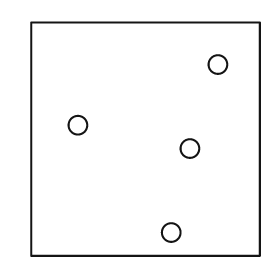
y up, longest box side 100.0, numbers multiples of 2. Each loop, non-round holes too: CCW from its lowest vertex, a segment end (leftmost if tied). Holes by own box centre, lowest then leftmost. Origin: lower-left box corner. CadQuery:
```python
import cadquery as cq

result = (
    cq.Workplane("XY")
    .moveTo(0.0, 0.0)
    .lineTo(98.0, 0.0)
    .lineTo(98.0, 100.0)
    .lineTo(0.0, 100.0)
    .close()
    .moveTo(60.0, 10.0)
    .circle(4.0)
    .moveTo(68.0, 46.0)
    .circle(4.0)
    .moveTo(20.0, 56.0)
    .circle(4.0)
    .moveTo(80.0, 82.0)
    .circle(4.0)
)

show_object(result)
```